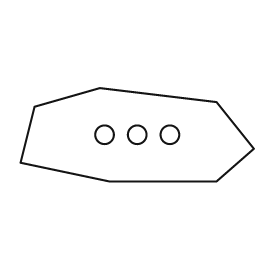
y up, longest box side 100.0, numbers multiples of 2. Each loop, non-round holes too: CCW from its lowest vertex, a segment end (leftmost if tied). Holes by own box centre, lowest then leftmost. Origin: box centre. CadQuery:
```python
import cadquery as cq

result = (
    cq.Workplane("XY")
    .moveTo(-12.0, -20.0)
    .lineTo(34.0, -20.0)
    .lineTo(50.0, -6.0)
    .lineTo(34.0, 14.0)
    .lineTo(-16.0, 20.0)
    .lineTo(-44.0, 12.0)
    .lineTo(-50.0, -12.0)
    .close()
    .moveTo(-14.0, 0.0)
    .circle(4.0)
    .moveTo(0.0, 0.0)
    .circle(4.0)
    .moveTo(14.0, 0.0)
    .circle(4.0)
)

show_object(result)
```